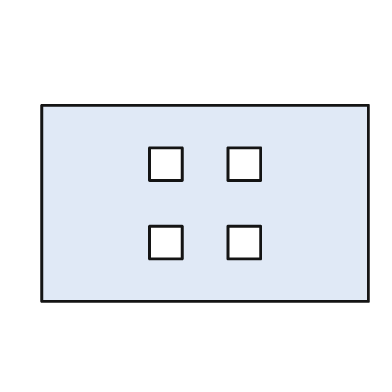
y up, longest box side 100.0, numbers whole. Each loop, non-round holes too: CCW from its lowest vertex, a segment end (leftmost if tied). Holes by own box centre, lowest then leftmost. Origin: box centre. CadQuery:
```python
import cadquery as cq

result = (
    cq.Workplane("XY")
    .moveTo(-50.0, -30.0)
    .lineTo(50.0, -30.0)
    .lineTo(50.0, 30.0)
    .lineTo(-50.0, 30.0)
    .close()
    .moveTo(-17.0, -17.0)
    .lineTo(-7.0, -17.0)
    .lineTo(-7.0, -7.0)
    .lineTo(-17.0, -7.0)
    .close()
    .moveTo(7.0, -17.0)
    .lineTo(17.0, -17.0)
    .lineTo(17.0, -7.0)
    .lineTo(7.0, -7.0)
    .close()
    .moveTo(-17.0, 7.0)
    .lineTo(-7.0, 7.0)
    .lineTo(-7.0, 17.0)
    .lineTo(-17.0, 17.0)
    .close()
    .moveTo(7.0, 7.0)
    .lineTo(17.0, 7.0)
    .lineTo(17.0, 17.0)
    .lineTo(7.0, 17.0)
    .close()
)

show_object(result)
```